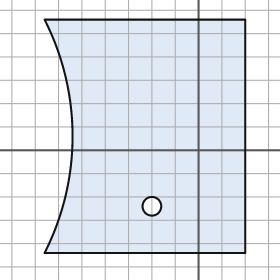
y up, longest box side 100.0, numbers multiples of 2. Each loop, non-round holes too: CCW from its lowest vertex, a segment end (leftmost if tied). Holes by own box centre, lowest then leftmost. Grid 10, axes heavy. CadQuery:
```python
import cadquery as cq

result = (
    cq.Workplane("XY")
    .moveTo(-66.0, -44.0)
    .lineTo(20.0, -44.0)
    .lineTo(20.0, 56.0)
    .lineTo(-66.0, 56.0)
    .threePointArc((-54.0, 6.0), (-66.0, -44.0))
    .close()
    .moveTo(-20.0, -24.0)
    .circle(4.0)
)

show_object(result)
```